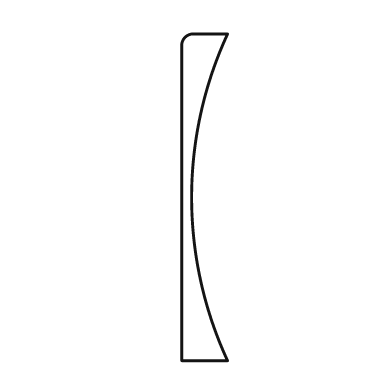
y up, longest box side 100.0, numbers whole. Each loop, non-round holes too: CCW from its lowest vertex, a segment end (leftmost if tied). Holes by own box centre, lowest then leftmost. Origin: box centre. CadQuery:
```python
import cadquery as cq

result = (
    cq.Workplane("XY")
    .moveTo(-7.0, -50.0)
    .lineTo(7.0, -50.0)
    .threePointArc((-4.0, 0.0), (7.0, 50.0))
    .lineTo(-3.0, 50.0)
    .threePointArc((-6.0, 49.0), (-7.0, 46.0))
    .close()
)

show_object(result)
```